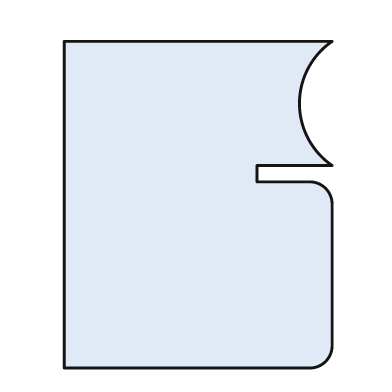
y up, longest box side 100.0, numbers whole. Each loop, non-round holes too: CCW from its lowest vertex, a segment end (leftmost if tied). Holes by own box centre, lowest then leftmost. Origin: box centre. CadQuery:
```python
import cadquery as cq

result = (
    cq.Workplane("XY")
    .moveTo(-41.0, -50.0)
    .lineTo(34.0, -50.0)
    .threePointArc((39.0, -48.0), (41.0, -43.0))
    .lineTo(41.0, 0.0)
    .threePointArc((39.0, 5.0), (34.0, 7.0))
    .lineTo(18.0, 7.0)
    .lineTo(18.0, 12.0)
    .lineTo(41.0, 12.0)
    .threePointArc((31.0, 31.0), (41.0, 50.0))
    .lineTo(-41.0, 50.0)
    .close()
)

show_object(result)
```